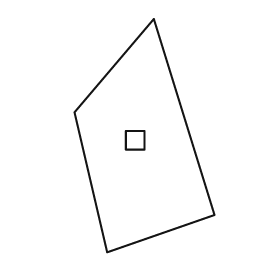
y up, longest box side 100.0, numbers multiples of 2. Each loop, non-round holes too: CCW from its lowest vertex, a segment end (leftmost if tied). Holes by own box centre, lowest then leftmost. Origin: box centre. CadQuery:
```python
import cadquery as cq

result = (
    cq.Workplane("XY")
    .moveTo(-16.0, -50.0)
    .lineTo(30.0, -34.0)
    .lineTo(4.0, 50.0)
    .lineTo(-30.0, 10.0)
    .close()
    .moveTo(-8.0, -6.0)
    .lineTo(0.0, -6.0)
    .lineTo(0.0, 2.0)
    .lineTo(-8.0, 2.0)
    .close()
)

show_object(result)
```